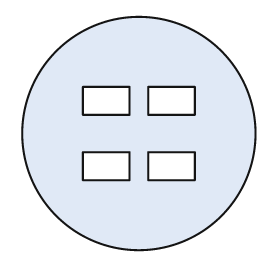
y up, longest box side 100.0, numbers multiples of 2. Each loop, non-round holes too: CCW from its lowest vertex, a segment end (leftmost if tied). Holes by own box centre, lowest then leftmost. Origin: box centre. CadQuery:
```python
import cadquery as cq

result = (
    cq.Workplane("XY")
    .moveTo(0.0, 0.0)
    .circle(50.0)
    .moveTo(-24.0, -20.0)
    .lineTo(-4.0, -20.0)
    .lineTo(-4.0, -8.0)
    .lineTo(-24.0, -8.0)
    .close()
    .moveTo(4.0, -20.0)
    .lineTo(24.0, -20.0)
    .lineTo(24.0, -8.0)
    .lineTo(4.0, -8.0)
    .close()
    .moveTo(-24.0, 8.0)
    .lineTo(-4.0, 8.0)
    .lineTo(-4.0, 20.0)
    .lineTo(-24.0, 20.0)
    .close()
    .moveTo(4.0, 8.0)
    .lineTo(24.0, 8.0)
    .lineTo(24.0, 20.0)
    .lineTo(4.0, 20.0)
    .close()
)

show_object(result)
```